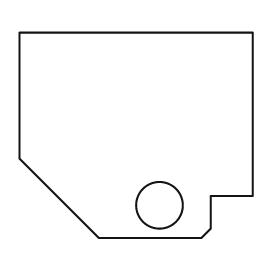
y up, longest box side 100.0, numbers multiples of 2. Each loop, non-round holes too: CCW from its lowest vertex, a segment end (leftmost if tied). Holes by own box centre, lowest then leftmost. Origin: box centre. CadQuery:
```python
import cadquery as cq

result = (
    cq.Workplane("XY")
    .moveTo(-16.0, -44.0)
    .lineTo(28.0, -44.0)
    .lineTo(32.0, -40.0)
    .lineTo(32.0, -26.0)
    .lineTo(50.0, -26.0)
    .lineTo(50.0, 44.0)
    .lineTo(-50.0, 44.0)
    .lineTo(-50.0, -10.0)
    .close()
    .moveTo(10.0, -30.0)
    .circle(10.0)
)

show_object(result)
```